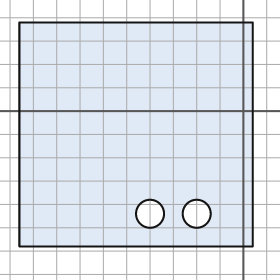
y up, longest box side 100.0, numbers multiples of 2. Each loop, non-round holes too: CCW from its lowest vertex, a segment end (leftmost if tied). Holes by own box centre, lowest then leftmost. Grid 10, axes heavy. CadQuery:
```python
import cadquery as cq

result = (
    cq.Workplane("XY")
    .moveTo(-96.0, -58.0)
    .lineTo(4.0, -58.0)
    .lineTo(4.0, 38.0)
    .lineTo(-96.0, 38.0)
    .close()
    .moveTo(-40.0, -44.0)
    .circle(6.0)
    .moveTo(-20.0, -44.0)
    .circle(6.0)
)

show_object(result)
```